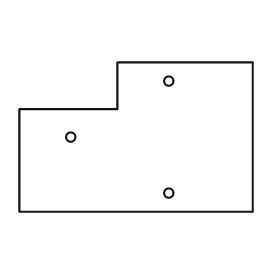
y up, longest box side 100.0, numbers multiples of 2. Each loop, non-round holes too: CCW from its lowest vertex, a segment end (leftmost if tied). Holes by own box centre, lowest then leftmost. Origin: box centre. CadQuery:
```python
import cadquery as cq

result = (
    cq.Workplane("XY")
    .moveTo(-50.0, -32.0)
    .lineTo(50.0, -32.0)
    .lineTo(50.0, 32.0)
    .lineTo(-8.0, 32.0)
    .lineTo(-8.0, 12.0)
    .lineTo(-50.0, 12.0)
    .close()
    .moveTo(14.0, -24.0)
    .circle(2.0)
    .moveTo(-28.0, 0.0)
    .circle(2.0)
    .moveTo(14.0, 24.0)
    .circle(2.0)
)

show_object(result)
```